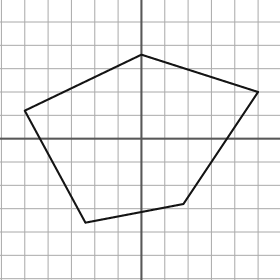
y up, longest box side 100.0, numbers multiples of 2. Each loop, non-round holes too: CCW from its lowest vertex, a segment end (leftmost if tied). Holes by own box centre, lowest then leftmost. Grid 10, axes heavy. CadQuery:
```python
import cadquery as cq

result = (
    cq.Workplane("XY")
    .moveTo(-24.0, -36.0)
    .lineTo(18.0, -28.0)
    .lineTo(50.0, 20.0)
    .lineTo(0.0, 36.0)
    .lineTo(-50.0, 12.0)
    .close()
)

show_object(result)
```